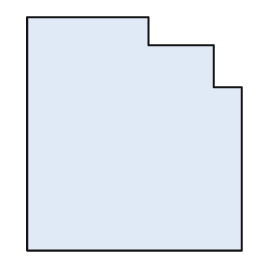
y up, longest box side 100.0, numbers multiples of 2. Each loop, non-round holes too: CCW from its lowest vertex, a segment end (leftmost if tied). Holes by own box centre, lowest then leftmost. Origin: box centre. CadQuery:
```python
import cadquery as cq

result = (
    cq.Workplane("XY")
    .moveTo(-46.0, -50.0)
    .lineTo(46.0, -50.0)
    .lineTo(46.0, 20.0)
    .lineTo(34.0, 20.0)
    .lineTo(34.0, 38.0)
    .lineTo(6.0, 38.0)
    .lineTo(6.0, 50.0)
    .lineTo(-46.0, 50.0)
    .close()
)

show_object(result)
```